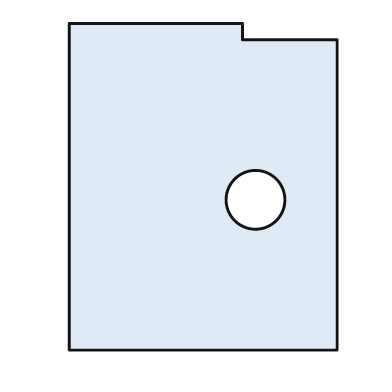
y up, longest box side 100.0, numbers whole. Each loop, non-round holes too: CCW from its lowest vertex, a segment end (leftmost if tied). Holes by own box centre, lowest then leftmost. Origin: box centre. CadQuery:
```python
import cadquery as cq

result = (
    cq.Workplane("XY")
    .moveTo(-41.0, -50.0)
    .lineTo(41.0, -50.0)
    .lineTo(41.0, 45.0)
    .lineTo(12.0, 45.0)
    .lineTo(12.0, 50.0)
    .lineTo(-41.0, 50.0)
    .close()
    .moveTo(16.0, -4.0)
    .circle(9.0)
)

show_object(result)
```